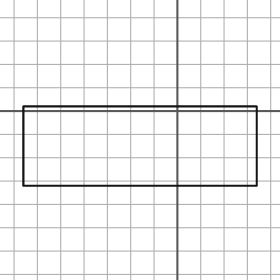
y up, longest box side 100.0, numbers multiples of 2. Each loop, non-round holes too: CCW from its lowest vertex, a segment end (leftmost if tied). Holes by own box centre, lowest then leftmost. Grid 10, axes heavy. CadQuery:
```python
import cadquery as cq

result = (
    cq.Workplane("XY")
    .moveTo(-66.0, -32.0)
    .lineTo(34.0, -32.0)
    .lineTo(34.0, 2.0)
    .lineTo(-66.0, 2.0)
    .close()
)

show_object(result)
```